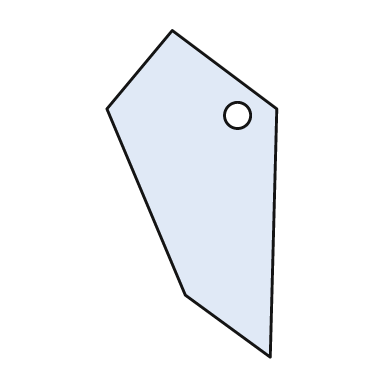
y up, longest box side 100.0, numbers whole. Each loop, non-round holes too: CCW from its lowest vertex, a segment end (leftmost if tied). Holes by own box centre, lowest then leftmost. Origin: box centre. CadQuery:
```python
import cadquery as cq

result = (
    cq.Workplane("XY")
    .moveTo(24.0, -50.0)
    .lineTo(26.0, 26.0)
    .lineTo(-6.0, 50.0)
    .lineTo(-26.0, 26.0)
    .lineTo(-2.0, -31.0)
    .close()
    .moveTo(14.0, 24.0)
    .circle(4.0)
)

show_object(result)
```